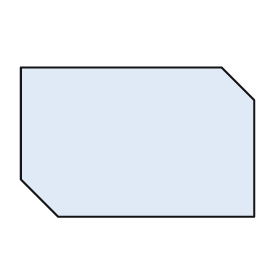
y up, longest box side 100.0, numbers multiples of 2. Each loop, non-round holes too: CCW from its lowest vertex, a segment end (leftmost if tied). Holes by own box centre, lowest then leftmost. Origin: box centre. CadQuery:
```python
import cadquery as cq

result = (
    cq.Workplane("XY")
    .moveTo(-34.0, -32.0)
    .lineTo(50.0, -32.0)
    .lineTo(50.0, 18.0)
    .lineTo(36.0, 32.0)
    .lineTo(-50.0, 32.0)
    .lineTo(-50.0, -16.0)
    .close()
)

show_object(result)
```